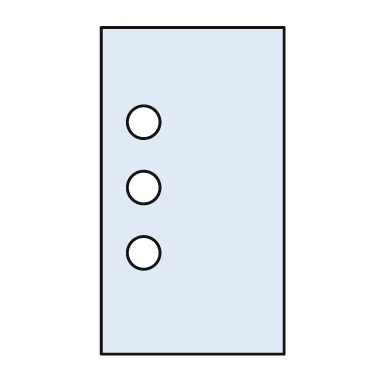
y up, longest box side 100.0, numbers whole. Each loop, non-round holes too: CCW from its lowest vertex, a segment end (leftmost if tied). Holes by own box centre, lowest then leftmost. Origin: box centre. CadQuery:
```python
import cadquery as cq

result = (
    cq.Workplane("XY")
    .moveTo(-28.0, -50.0)
    .lineTo(28.0, -50.0)
    .lineTo(28.0, 50.0)
    .lineTo(-28.0, 50.0)
    .close()
    .moveTo(-15.0, -19.0)
    .circle(5.0)
    .moveTo(-15.0, 1.0)
    .circle(5.0)
    .moveTo(-15.0, 21.0)
    .circle(5.0)
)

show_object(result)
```